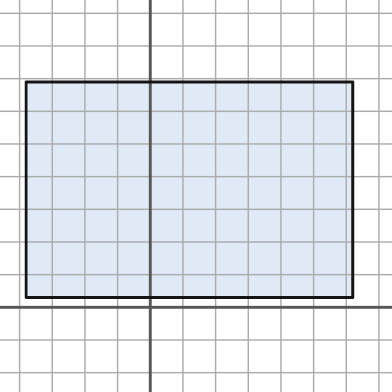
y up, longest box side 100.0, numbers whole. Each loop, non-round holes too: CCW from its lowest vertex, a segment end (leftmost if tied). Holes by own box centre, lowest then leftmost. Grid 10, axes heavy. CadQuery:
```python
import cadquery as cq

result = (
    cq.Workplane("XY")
    .moveTo(-38.0, 3.0)
    .lineTo(62.0, 3.0)
    .lineTo(62.0, 69.0)
    .lineTo(-38.0, 69.0)
    .close()
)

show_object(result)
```